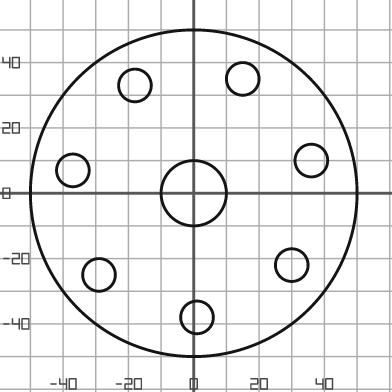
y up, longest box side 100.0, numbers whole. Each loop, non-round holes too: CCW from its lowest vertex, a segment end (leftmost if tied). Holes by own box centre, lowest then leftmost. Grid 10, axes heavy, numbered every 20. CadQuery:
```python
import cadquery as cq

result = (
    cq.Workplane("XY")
    .moveTo(0.0, 0.0)
    .circle(50.0)
    .moveTo(1.0, -38.0)
    .circle(5.0)
    .moveTo(-29.0, -25.0)
    .circle(5.0)
    .moveTo(30.0, -22.0)
    .circle(5.0)
    .moveTo(0.0, 0.0)
    .circle(10.0)
    .moveTo(-37.0, 7.0)
    .circle(5.0)
    .moveTo(36.0, 10.0)
    .circle(5.0)
    .moveTo(-18.0, 33.0)
    .circle(5.0)
    .moveTo(15.0, 35.0)
    .circle(5.0)
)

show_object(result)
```